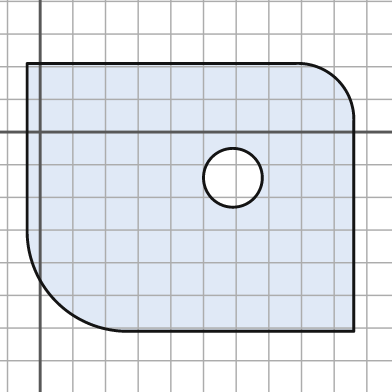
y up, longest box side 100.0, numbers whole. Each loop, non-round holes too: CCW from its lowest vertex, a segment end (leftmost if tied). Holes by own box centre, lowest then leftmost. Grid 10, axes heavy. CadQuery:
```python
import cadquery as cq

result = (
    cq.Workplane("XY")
    .moveTo(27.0, -61.0)
    .lineTo(96.0, -61.0)
    .lineTo(96.0, 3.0)
    .threePointArc((91.0, 16.0), (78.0, 21.0))
    .lineTo(-4.0, 21.0)
    .lineTo(-4.0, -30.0)
    .threePointArc((5.0, -52.0), (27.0, -61.0))
    .close()
    .moveTo(59.0, -14.0)
    .circle(9.0)
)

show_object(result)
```